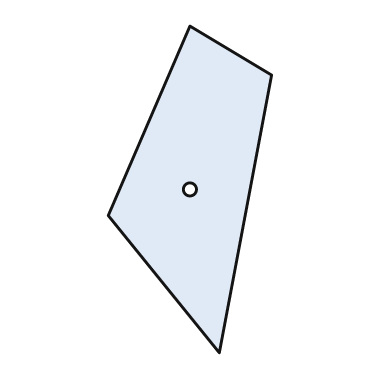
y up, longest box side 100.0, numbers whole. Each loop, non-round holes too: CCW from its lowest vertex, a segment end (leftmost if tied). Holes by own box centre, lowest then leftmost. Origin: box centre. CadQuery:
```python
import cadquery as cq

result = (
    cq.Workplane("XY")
    .moveTo(9.0, -50.0)
    .lineTo(25.0, 35.0)
    .lineTo(0.0, 50.0)
    .lineTo(-25.0, -8.0)
    .close()
    .moveTo(0.0, 0.0)
    .circle(2.0)
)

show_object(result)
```